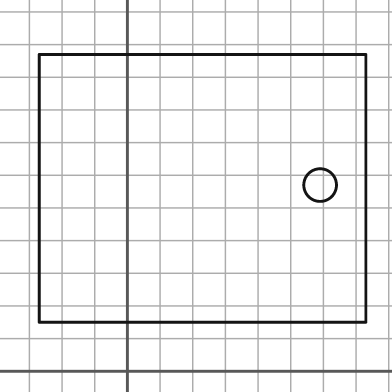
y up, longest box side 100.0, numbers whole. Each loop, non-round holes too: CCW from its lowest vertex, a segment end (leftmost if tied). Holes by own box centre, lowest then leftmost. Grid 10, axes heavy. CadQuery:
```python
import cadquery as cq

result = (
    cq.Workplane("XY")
    .moveTo(-27.0, 15.0)
    .lineTo(73.0, 15.0)
    .lineTo(73.0, 97.0)
    .lineTo(-27.0, 97.0)
    .close()
    .moveTo(59.0, 57.0)
    .circle(5.0)
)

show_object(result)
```